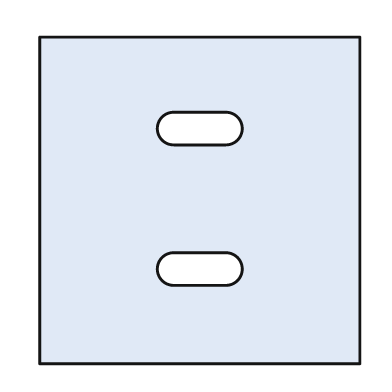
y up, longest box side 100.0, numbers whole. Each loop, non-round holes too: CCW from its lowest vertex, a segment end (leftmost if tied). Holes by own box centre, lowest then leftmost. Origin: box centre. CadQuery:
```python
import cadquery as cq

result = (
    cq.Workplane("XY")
    .moveTo(-49.0, -50.0)
    .lineTo(49.0, -50.0)
    .lineTo(49.0, 50.0)
    .lineTo(-49.0, 50.0)
    .close()
    .moveTo(-8.0, -26.0)
    .lineTo(8.0, -26.0)
    .threePointArc((13.0, -21.0), (8.0, -16.0))
    .lineTo(-8.0, -16.0)
    .threePointArc((-13.0, -21.0), (-8.0, -26.0))
    .close()
    .moveTo(-8.0, 17.0)
    .lineTo(8.0, 17.0)
    .threePointArc((13.0, 22.0), (8.0, 27.0))
    .lineTo(-8.0, 27.0)
    .threePointArc((-13.0, 22.0), (-8.0, 17.0))
    .close()
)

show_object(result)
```